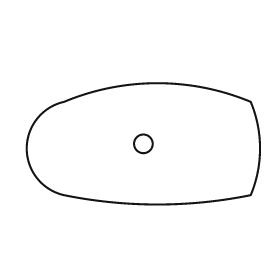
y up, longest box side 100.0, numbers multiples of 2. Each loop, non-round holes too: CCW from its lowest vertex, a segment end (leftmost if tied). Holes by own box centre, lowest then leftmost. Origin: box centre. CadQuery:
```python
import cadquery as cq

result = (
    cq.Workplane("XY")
    .moveTo(-34.0, -22.0)
    .threePointArc((6.0, -26.0), (46.0, -22.0))
    .threePointArc((50.0, -2.0), (46.0, 18.0))
    .threePointArc((6.0, 26.0), (-34.0, 18.0))
    .threePointArc((-50.0, -2.0), (-34.0, -22.0))
    .close()
    .moveTo(0.0, 0.0)
    .circle(4.0)
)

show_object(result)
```